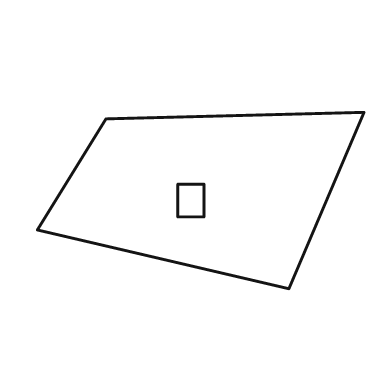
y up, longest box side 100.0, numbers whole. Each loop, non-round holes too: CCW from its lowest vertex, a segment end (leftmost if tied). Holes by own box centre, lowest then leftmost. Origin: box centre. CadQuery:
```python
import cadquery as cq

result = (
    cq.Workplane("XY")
    .moveTo(27.0, -27.0)
    .lineTo(50.0, 27.0)
    .lineTo(-29.0, 25.0)
    .lineTo(-50.0, -9.0)
    .close()
    .moveTo(-7.0, -5.0)
    .lineTo(1.0, -5.0)
    .lineTo(1.0, 5.0)
    .lineTo(-7.0, 5.0)
    .close()
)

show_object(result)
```